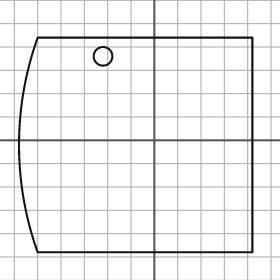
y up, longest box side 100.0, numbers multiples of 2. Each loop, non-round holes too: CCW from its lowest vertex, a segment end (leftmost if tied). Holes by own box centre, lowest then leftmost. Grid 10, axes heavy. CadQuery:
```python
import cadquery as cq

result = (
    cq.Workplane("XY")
    .moveTo(-50.0, -48.0)
    .lineTo(42.0, -48.0)
    .lineTo(42.0, 44.0)
    .lineTo(-50.0, 44.0)
    .threePointArc((-58.0, -2.0), (-50.0, -48.0))
    .close()
    .moveTo(-22.0, 36.0)
    .circle(4.0)
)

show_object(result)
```